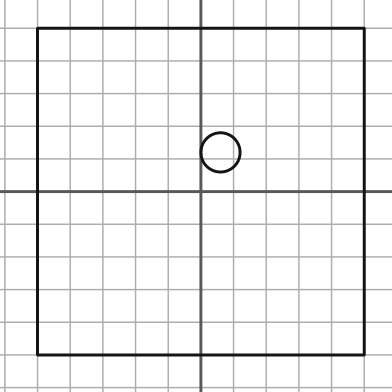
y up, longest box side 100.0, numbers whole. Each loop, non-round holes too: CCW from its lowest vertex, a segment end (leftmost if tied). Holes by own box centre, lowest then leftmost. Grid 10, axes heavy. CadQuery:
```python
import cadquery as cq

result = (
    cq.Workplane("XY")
    .moveTo(-50.0, -50.0)
    .lineTo(50.0, -50.0)
    .lineTo(50.0, 50.0)
    .lineTo(-50.0, 50.0)
    .close()
    .moveTo(6.0, 12.0)
    .circle(6.0)
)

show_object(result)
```